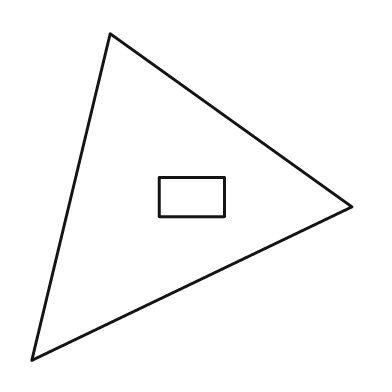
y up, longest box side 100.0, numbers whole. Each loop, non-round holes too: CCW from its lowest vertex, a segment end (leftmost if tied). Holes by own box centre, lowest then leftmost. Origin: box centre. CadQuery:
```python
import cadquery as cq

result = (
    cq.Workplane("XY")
    .moveTo(-49.0, -50.0)
    .lineTo(49.0, -3.0)
    .lineTo(-25.0, 50.0)
    .close()
    .moveTo(-10.0, -6.0)
    .lineTo(10.0, -6.0)
    .lineTo(10.0, 6.0)
    .lineTo(-10.0, 6.0)
    .close()
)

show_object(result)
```